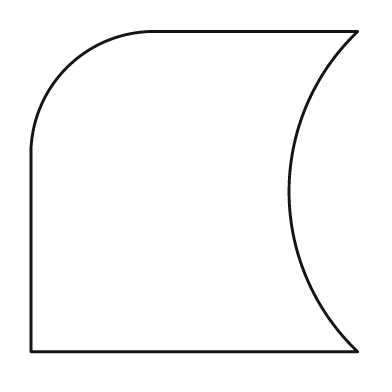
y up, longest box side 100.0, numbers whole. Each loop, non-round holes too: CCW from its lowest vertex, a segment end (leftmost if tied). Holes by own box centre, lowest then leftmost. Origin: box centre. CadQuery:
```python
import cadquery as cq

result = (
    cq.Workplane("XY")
    .moveTo(-50.0, -49.0)
    .lineTo(50.0, -49.0)
    .threePointArc((29.0, 0.0), (50.0, 49.0))
    .lineTo(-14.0, 49.0)
    .threePointArc((-39.0, 38.0), (-50.0, 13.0))
    .close()
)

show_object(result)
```